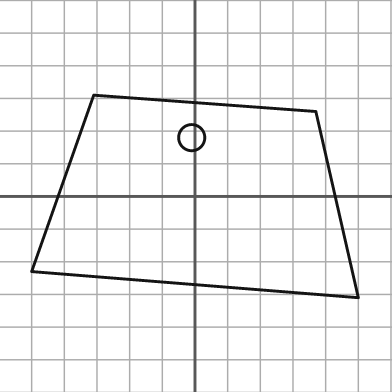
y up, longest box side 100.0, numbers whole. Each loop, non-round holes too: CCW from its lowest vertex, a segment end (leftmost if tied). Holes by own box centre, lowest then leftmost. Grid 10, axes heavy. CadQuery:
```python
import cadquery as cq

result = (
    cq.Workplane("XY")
    .moveTo(50.0, -31.0)
    .lineTo(37.0, 26.0)
    .lineTo(-31.0, 31.0)
    .lineTo(-50.0, -23.0)
    .close()
    .moveTo(-1.0, 18.0)
    .circle(4.0)
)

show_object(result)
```